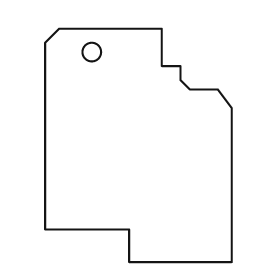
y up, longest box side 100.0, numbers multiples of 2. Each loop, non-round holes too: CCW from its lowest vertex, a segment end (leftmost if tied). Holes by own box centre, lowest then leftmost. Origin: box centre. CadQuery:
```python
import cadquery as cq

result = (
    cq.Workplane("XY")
    .moveTo(-4.0, -50.0)
    .lineTo(40.0, -50.0)
    .lineTo(40.0, 16.0)
    .lineTo(34.0, 24.0)
    .lineTo(22.0, 24.0)
    .lineTo(18.0, 28.0)
    .lineTo(18.0, 34.0)
    .lineTo(10.0, 34.0)
    .lineTo(10.0, 50.0)
    .lineTo(-34.0, 50.0)
    .lineTo(-40.0, 44.0)
    .lineTo(-40.0, -36.0)
    .lineTo(-4.0, -36.0)
    .close()
    .moveTo(-20.0, 40.0)
    .circle(4.0)
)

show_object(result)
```